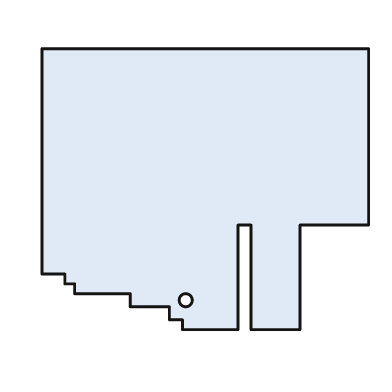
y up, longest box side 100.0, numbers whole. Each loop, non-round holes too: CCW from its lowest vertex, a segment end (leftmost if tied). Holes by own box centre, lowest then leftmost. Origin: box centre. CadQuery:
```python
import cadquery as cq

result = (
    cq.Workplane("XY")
    .moveTo(-7.0, -43.0)
    .lineTo(10.0, -43.0)
    .lineTo(10.0, -11.0)
    .lineTo(14.0, -11.0)
    .lineTo(14.0, -43.0)
    .lineTo(29.0, -43.0)
    .lineTo(29.0, -11.0)
    .lineTo(50.0, -11.0)
    .lineTo(50.0, 43.0)
    .lineTo(-50.0, 43.0)
    .lineTo(-50.0, -26.0)
    .lineTo(-43.0, -26.0)
    .lineTo(-43.0, -29.0)
    .lineTo(-40.0, -29.0)
    .lineTo(-40.0, -32.0)
    .lineTo(-23.0, -32.0)
    .lineTo(-23.0, -36.0)
    .lineTo(-11.0, -36.0)
    .lineTo(-11.0, -40.0)
    .lineTo(-7.0, -40.0)
    .close()
    .moveTo(-6.0, -34.0)
    .circle(2.0)
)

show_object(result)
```